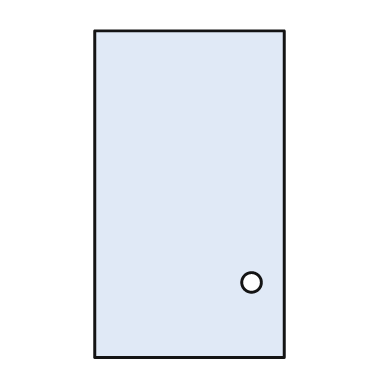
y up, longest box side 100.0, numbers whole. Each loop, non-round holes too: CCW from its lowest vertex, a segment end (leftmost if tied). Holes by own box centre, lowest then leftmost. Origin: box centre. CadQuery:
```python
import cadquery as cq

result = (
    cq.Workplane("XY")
    .moveTo(-29.0, -50.0)
    .lineTo(29.0, -50.0)
    .lineTo(29.0, 50.0)
    .lineTo(-29.0, 50.0)
    .close()
    .moveTo(19.0, -27.0)
    .circle(3.0)
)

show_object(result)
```